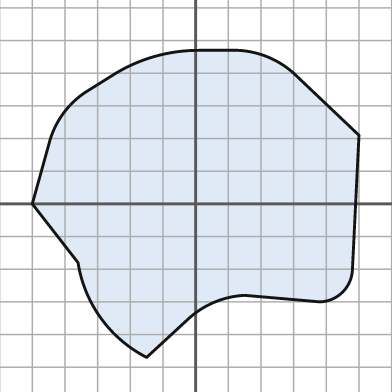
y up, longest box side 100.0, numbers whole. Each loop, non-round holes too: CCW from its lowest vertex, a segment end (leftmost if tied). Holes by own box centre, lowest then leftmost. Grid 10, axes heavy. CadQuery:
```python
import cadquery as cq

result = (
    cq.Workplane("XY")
    .moveTo(-15.0, -47.0)
    .lineTo(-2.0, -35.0)
    .threePointArc((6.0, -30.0), (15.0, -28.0))
    .lineTo(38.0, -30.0)
    .threePointArc((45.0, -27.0), (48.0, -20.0))
    .lineTo(50.0, 21.0)
    .lineTo(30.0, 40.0)
    .threePointArc((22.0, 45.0), (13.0, 47.0))
    .lineTo(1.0, 47.0)
    .threePointArc((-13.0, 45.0), (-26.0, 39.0))
    .lineTo(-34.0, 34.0)
    .threePointArc((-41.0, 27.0), (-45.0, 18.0))
    .lineTo(-50.0, 0.0)
    .lineTo(-36.0, -18.0)
    .threePointArc((-29.0, -35.0), (-15.0, -47.0))
    .close()
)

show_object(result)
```